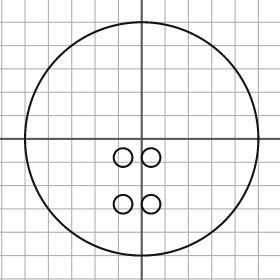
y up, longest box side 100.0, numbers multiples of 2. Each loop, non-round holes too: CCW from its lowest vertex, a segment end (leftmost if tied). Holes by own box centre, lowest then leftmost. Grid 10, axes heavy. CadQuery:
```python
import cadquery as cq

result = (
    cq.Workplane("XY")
    .moveTo(0.0, 0.0)
    .circle(50.0)
    .moveTo(-8.0, -28.0)
    .circle(4.0)
    .moveTo(4.0, -28.0)
    .circle(4.0)
    .moveTo(-8.0, -8.0)
    .circle(4.0)
    .moveTo(4.0, -8.0)
    .circle(4.0)
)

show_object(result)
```